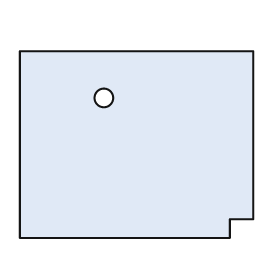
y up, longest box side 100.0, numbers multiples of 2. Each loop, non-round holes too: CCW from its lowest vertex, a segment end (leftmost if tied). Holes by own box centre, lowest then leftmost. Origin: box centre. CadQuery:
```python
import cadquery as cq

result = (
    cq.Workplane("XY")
    .moveTo(-50.0, -40.0)
    .lineTo(40.0, -40.0)
    .lineTo(40.0, -32.0)
    .lineTo(50.0, -32.0)
    .lineTo(50.0, 40.0)
    .lineTo(-50.0, 40.0)
    .close()
    .moveTo(-14.0, 20.0)
    .circle(4.0)
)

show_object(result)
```